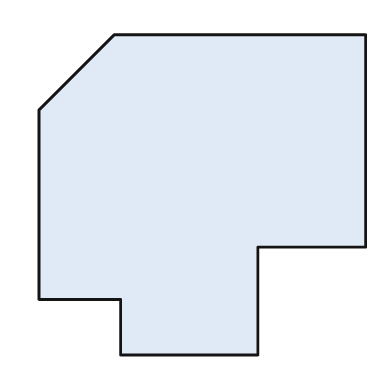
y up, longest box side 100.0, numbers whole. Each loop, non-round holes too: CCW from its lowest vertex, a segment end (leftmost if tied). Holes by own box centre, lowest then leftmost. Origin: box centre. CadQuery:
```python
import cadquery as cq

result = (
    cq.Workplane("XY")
    .moveTo(-25.0, -49.0)
    .lineTo(17.0, -49.0)
    .lineTo(17.0, -16.0)
    .lineTo(50.0, -16.0)
    .lineTo(50.0, 49.0)
    .lineTo(-27.0, 49.0)
    .lineTo(-50.0, 26.0)
    .lineTo(-50.0, -32.0)
    .lineTo(-25.0, -32.0)
    .close()
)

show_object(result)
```